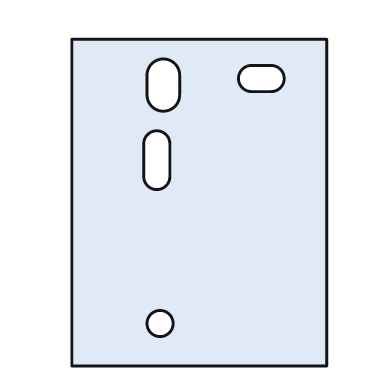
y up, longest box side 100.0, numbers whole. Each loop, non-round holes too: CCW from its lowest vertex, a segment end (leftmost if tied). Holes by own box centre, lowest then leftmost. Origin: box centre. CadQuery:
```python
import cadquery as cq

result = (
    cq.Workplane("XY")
    .moveTo(-39.0, -50.0)
    .lineTo(39.0, -50.0)
    .lineTo(39.0, 50.0)
    .lineTo(-39.0, 50.0)
    .close()
    .moveTo(-12.0, -37.0)
    .circle(4.0)
    .moveTo(-17.0, 8.0)
    .threePointArc((-13.0, 4.0), (-9.0, 8.0))
    .lineTo(-9.0, 18.0)
    .threePointArc((-13.0, 22.0), (-17.0, 18.0))
    .close()
    .moveTo(-16.0, 33.0)
    .threePointArc((-11.0, 28.0), (-6.0, 33.0))
    .lineTo(-6.0, 39.0)
    .threePointArc((-11.0, 44.0), (-16.0, 39.0))
    .close()
    .moveTo(16.0, 34.0)
    .lineTo(22.0, 34.0)
    .threePointArc((26.0, 38.0), (22.0, 42.0))
    .lineTo(16.0, 42.0)
    .threePointArc((12.0, 38.0), (16.0, 34.0))
    .close()
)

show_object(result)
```